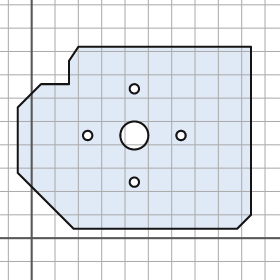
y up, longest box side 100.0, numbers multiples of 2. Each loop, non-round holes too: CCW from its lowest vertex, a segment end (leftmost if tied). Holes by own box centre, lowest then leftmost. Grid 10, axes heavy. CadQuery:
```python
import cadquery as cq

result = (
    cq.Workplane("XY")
    .moveTo(18.0, 4.0)
    .lineTo(88.0, 4.0)
    .lineTo(94.0, 10.0)
    .lineTo(94.0, 82.0)
    .lineTo(20.0, 82.0)
    .lineTo(16.0, 76.0)
    .lineTo(16.0, 66.0)
    .lineTo(4.0, 66.0)
    .lineTo(-6.0, 56.0)
    .lineTo(-6.0, 28.0)
    .close()
    .moveTo(44.0, 24.0)
    .circle(2.0)
    .moveTo(24.0, 44.0)
    .circle(2.0)
    .moveTo(44.0, 44.0)
    .circle(6.0)
    .moveTo(64.0, 44.0)
    .circle(2.0)
    .moveTo(44.0, 64.0)
    .circle(2.0)
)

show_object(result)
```